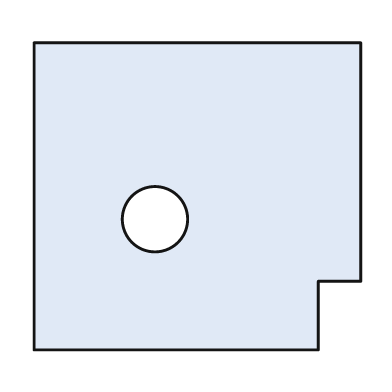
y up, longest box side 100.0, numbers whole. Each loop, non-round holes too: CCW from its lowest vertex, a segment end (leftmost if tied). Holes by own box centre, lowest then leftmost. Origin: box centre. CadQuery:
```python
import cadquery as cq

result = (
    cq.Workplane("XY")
    .moveTo(-50.0, -47.0)
    .lineTo(37.0, -47.0)
    .lineTo(37.0, -26.0)
    .lineTo(50.0, -26.0)
    .lineTo(50.0, 47.0)
    .lineTo(-50.0, 47.0)
    .close()
    .moveTo(-13.0, -7.0)
    .circle(10.0)
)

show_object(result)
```